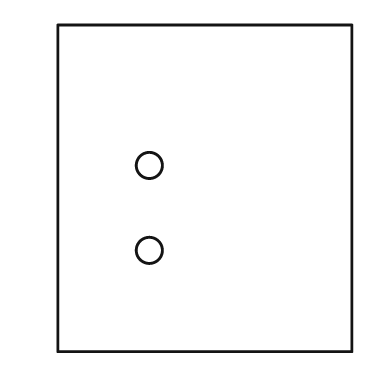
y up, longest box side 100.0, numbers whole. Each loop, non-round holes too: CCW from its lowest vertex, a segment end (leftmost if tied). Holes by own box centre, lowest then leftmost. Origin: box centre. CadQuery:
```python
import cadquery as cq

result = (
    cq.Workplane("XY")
    .moveTo(-45.0, -50.0)
    .lineTo(45.0, -50.0)
    .lineTo(45.0, 50.0)
    .lineTo(-45.0, 50.0)
    .close()
    .moveTo(-17.0, -19.0)
    .circle(4.0)
    .moveTo(-17.0, 7.0)
    .circle(4.0)
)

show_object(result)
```